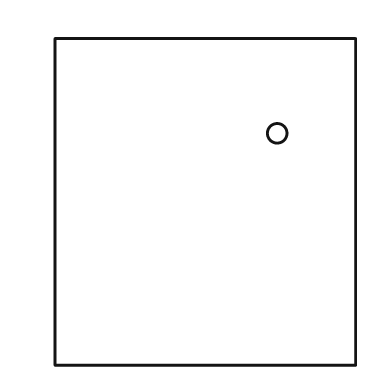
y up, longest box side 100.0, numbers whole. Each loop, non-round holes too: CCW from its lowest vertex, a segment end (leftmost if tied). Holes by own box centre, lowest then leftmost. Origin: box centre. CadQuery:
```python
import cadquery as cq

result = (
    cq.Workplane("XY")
    .moveTo(-46.0, -50.0)
    .lineTo(46.0, -50.0)
    .lineTo(46.0, 50.0)
    .lineTo(-46.0, 50.0)
    .close()
    .moveTo(22.0, 21.0)
    .circle(3.0)
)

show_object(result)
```